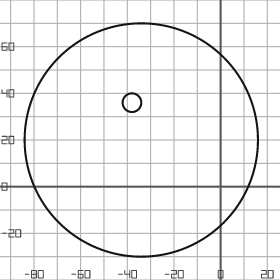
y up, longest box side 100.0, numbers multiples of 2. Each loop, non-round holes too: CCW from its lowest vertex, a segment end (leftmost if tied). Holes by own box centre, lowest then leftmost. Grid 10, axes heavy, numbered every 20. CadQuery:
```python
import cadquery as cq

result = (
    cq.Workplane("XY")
    .moveTo(-34.0, 20.0)
    .circle(50.0)
    .moveTo(-38.0, 36.0)
    .circle(4.0)
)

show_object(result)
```